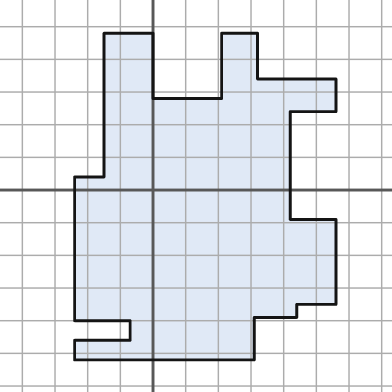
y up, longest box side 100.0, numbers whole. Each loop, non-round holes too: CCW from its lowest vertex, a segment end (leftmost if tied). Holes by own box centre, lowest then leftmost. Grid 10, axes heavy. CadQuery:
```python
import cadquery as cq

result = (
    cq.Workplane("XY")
    .moveTo(-24.0, -52.0)
    .lineTo(31.0, -52.0)
    .lineTo(31.0, -39.0)
    .lineTo(44.0, -39.0)
    .lineTo(44.0, -35.0)
    .lineTo(56.0, -35.0)
    .lineTo(56.0, -9.0)
    .lineTo(42.0, -9.0)
    .lineTo(42.0, 24.0)
    .lineTo(56.0, 24.0)
    .lineTo(56.0, 34.0)
    .lineTo(32.0, 34.0)
    .lineTo(32.0, 48.0)
    .lineTo(21.0, 48.0)
    .lineTo(21.0, 28.0)
    .lineTo(0.0, 28.0)
    .lineTo(0.0, 48.0)
    .lineTo(-15.0, 48.0)
    .lineTo(-15.0, 4.0)
    .lineTo(-24.0, 4.0)
    .lineTo(-24.0, -40.0)
    .lineTo(-7.0, -40.0)
    .lineTo(-7.0, -46.0)
    .lineTo(-24.0, -46.0)
    .close()
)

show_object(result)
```